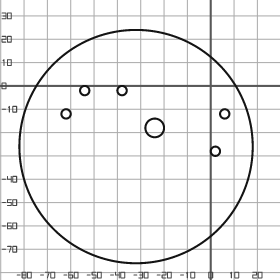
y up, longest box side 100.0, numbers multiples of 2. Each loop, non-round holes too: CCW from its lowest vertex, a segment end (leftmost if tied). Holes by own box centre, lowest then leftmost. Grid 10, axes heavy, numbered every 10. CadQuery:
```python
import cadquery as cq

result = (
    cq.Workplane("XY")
    .moveTo(-32.0, -26.0)
    .circle(50.0)
    .moveTo(2.0, -28.0)
    .circle(2.0)
    .moveTo(-24.0, -18.0)
    .circle(4.0)
    .moveTo(-62.0, -12.0)
    .circle(2.0)
    .moveTo(6.0, -12.0)
    .circle(2.0)
    .moveTo(-54.0, -2.0)
    .circle(2.0)
    .moveTo(-38.0, -2.0)
    .circle(2.0)
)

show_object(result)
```